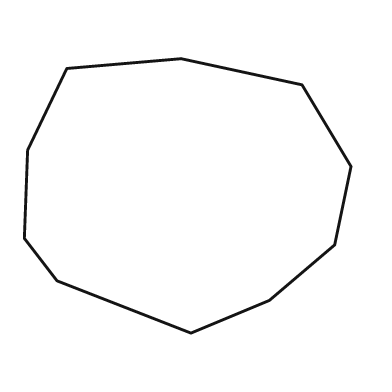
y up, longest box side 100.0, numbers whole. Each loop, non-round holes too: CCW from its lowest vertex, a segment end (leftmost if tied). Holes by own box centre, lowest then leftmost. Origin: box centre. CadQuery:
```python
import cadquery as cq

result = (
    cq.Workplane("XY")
    .moveTo(1.0, -42.0)
    .lineTo(25.0, -32.0)
    .lineTo(45.0, -15.0)
    .lineTo(50.0, 9.0)
    .lineTo(35.0, 34.0)
    .lineTo(-2.0, 42.0)
    .lineTo(-37.0, 39.0)
    .lineTo(-49.0, 14.0)
    .lineTo(-50.0, -13.0)
    .lineTo(-40.0, -26.0)
    .close()
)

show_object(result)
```